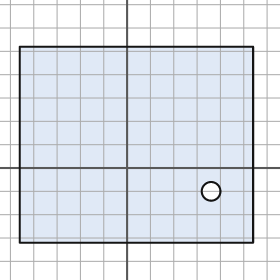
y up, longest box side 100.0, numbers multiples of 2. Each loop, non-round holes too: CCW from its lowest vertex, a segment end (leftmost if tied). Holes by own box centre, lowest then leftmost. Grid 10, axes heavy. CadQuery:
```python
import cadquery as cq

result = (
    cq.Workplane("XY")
    .moveTo(-46.0, -32.0)
    .lineTo(54.0, -32.0)
    .lineTo(54.0, 52.0)
    .lineTo(-46.0, 52.0)
    .close()
    .moveTo(36.0, -10.0)
    .circle(4.0)
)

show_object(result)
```